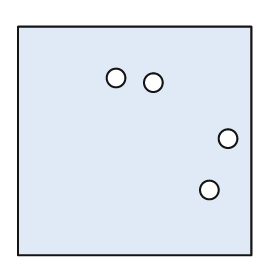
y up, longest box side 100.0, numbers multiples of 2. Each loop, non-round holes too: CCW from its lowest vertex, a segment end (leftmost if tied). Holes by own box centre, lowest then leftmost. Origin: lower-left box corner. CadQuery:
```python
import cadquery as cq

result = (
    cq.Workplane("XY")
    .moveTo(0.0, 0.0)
    .lineTo(100.0, 0.0)
    .lineTo(100.0, 98.0)
    .lineTo(0.0, 98.0)
    .close()
    .moveTo(82.0, 28.0)
    .circle(4.0)
    .moveTo(90.0, 50.0)
    .circle(4.0)
    .moveTo(58.0, 74.0)
    .circle(4.0)
    .moveTo(42.0, 76.0)
    .circle(4.0)
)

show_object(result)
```